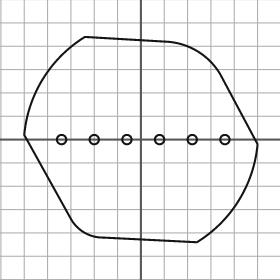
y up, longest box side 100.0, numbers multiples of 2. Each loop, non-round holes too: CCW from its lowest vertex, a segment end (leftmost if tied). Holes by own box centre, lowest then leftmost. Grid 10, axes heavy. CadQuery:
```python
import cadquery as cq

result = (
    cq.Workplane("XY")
    .moveTo(24.0, -44.0)
    .threePointArc((42.0, -26.0), (50.0, -2.0))
    .lineTo(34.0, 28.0)
    .threePointArc((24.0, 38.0), (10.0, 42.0))
    .lineTo(-24.0, 44.0)
    .threePointArc((-42.0, 26.0), (-50.0, 2.0))
    .lineTo(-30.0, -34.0)
    .threePointArc((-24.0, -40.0), (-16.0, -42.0))
    .close()
    .moveTo(-34.0, 0.0)
    .circle(2.0)
    .moveTo(-20.0, 0.0)
    .circle(2.0)
    .moveTo(-6.0, 0.0)
    .circle(2.0)
    .moveTo(8.0, 0.0)
    .circle(2.0)
    .moveTo(22.0, 0.0)
    .circle(2.0)
    .moveTo(36.0, 0.0)
    .circle(2.0)
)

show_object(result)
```